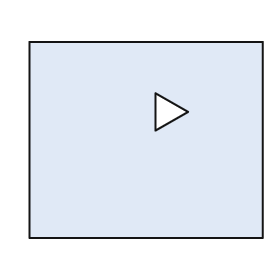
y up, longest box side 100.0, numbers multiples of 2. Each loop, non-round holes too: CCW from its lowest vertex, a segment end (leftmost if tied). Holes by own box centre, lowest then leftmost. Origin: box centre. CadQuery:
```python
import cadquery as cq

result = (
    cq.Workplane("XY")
    .moveTo(-50.0, -42.0)
    .lineTo(50.0, -42.0)
    .lineTo(50.0, 42.0)
    .lineTo(-50.0, 42.0)
    .close()
    .moveTo(4.0, 4.0)
    .lineTo(18.0, 12.0)
    .lineTo(4.0, 20.0)
    .close()
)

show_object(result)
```